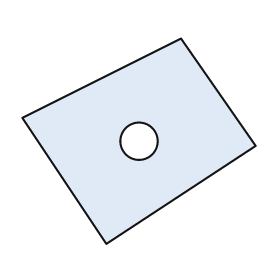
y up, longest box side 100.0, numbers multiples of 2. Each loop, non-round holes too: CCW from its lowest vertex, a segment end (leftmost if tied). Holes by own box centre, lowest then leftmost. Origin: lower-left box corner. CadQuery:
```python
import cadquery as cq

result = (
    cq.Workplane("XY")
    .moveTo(36.0, 0.0)
    .lineTo(100.0, 42.0)
    .lineTo(68.0, 88.0)
    .lineTo(0.0, 54.0)
    .close()
    .moveTo(50.0, 44.0)
    .circle(8.0)
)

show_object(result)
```